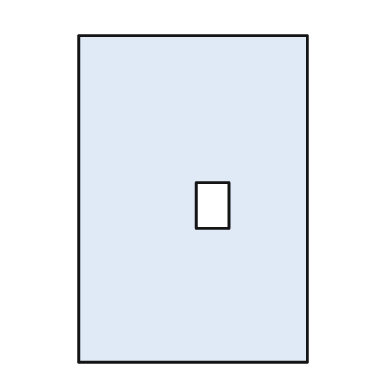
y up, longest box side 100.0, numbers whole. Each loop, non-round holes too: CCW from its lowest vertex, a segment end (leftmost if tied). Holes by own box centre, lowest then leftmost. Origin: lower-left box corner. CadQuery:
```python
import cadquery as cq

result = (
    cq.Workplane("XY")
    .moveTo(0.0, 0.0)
    .lineTo(70.0, 0.0)
    .lineTo(70.0, 100.0)
    .lineTo(0.0, 100.0)
    .close()
    .moveTo(36.0, 41.0)
    .lineTo(46.0, 41.0)
    .lineTo(46.0, 55.0)
    .lineTo(36.0, 55.0)
    .close()
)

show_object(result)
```